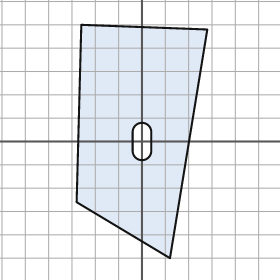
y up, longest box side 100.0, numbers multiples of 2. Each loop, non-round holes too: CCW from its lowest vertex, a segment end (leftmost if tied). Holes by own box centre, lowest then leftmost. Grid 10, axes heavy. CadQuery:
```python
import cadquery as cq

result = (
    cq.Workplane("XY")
    .moveTo(12.0, -50.0)
    .lineTo(28.0, 48.0)
    .lineTo(-26.0, 50.0)
    .lineTo(-28.0, -26.0)
    .close()
    .moveTo(-4.0, -4.0)
    .threePointArc((0.0, -8.0), (4.0, -4.0))
    .lineTo(4.0, 4.0)
    .threePointArc((0.0, 8.0), (-4.0, 4.0))
    .close()
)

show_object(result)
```